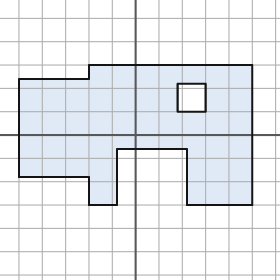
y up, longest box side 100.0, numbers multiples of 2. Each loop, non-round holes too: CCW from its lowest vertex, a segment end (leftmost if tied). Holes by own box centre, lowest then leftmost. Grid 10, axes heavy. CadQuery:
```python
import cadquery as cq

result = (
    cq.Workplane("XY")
    .moveTo(-20.0, -30.0)
    .lineTo(-8.0, -30.0)
    .lineTo(-8.0, -6.0)
    .lineTo(22.0, -6.0)
    .lineTo(22.0, -30.0)
    .lineTo(50.0, -30.0)
    .lineTo(50.0, 30.0)
    .lineTo(-20.0, 30.0)
    .lineTo(-20.0, 24.0)
    .lineTo(-50.0, 24.0)
    .lineTo(-50.0, -18.0)
    .lineTo(-20.0, -18.0)
    .close()
    .moveTo(18.0, 10.0)
    .lineTo(30.0, 10.0)
    .lineTo(30.0, 22.0)
    .lineTo(18.0, 22.0)
    .close()
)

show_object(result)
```